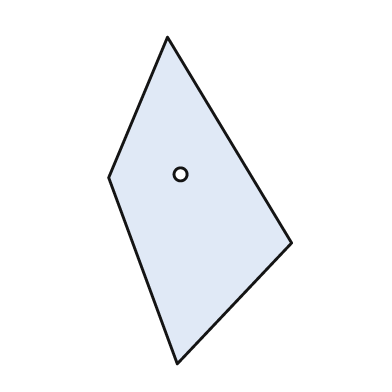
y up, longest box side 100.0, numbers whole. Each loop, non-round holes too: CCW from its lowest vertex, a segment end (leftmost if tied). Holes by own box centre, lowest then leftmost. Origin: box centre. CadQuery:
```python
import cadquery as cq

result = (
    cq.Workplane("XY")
    .moveTo(-7.0, -50.0)
    .lineTo(28.0, -13.0)
    .lineTo(-10.0, 50.0)
    .lineTo(-28.0, 7.0)
    .close()
    .moveTo(-6.0, 8.0)
    .circle(2.0)
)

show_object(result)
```